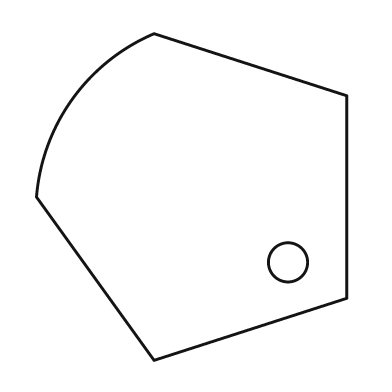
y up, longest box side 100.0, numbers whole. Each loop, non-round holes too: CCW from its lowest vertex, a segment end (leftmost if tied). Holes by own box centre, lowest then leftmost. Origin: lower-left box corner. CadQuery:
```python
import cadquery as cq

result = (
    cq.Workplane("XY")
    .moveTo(36.0, 0.0)
    .lineTo(95.0, 19.0)
    .lineTo(95.0, 81.0)
    .lineTo(36.0, 100.0)
    .threePointArc((11.0, 80.0), (0.0, 50.0))
    .close()
    .moveTo(77.0, 30.0)
    .circle(6.0)
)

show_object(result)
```